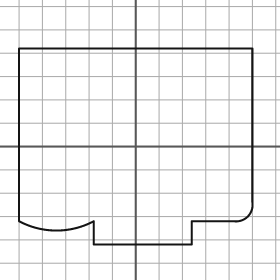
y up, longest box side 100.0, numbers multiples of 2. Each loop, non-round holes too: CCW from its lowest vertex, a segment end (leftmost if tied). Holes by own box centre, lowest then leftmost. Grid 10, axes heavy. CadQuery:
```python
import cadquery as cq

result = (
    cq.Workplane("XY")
    .moveTo(-18.0, -42.0)
    .lineTo(24.0, -42.0)
    .lineTo(24.0, -32.0)
    .lineTo(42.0, -32.0)
    .threePointArc((48.0, -30.0), (50.0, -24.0))
    .lineTo(50.0, 42.0)
    .lineTo(-50.0, 42.0)
    .lineTo(-50.0, -32.0)
    .threePointArc((-34.0, -36.0), (-18.0, -32.0))
    .close()
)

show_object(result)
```